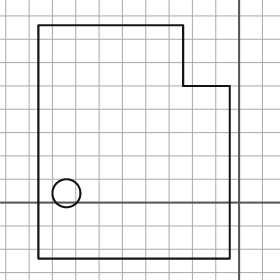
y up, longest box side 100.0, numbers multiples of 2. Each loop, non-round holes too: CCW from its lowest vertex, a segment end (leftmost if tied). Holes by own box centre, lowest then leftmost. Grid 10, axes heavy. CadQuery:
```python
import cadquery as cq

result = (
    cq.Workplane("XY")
    .moveTo(-86.0, -24.0)
    .lineTo(-4.0, -24.0)
    .lineTo(-4.0, 50.0)
    .lineTo(-24.0, 50.0)
    .lineTo(-24.0, 76.0)
    .lineTo(-86.0, 76.0)
    .close()
    .moveTo(-74.0, 4.0)
    .circle(6.0)
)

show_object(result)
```